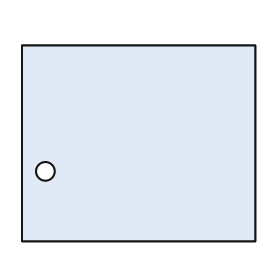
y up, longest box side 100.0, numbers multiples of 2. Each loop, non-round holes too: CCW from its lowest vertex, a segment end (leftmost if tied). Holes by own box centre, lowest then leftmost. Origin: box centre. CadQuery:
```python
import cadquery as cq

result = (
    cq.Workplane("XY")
    .moveTo(-50.0, -42.0)
    .lineTo(50.0, -42.0)
    .lineTo(50.0, 42.0)
    .lineTo(-50.0, 42.0)
    .close()
    .moveTo(-40.0, -12.0)
    .circle(4.0)
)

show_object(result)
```